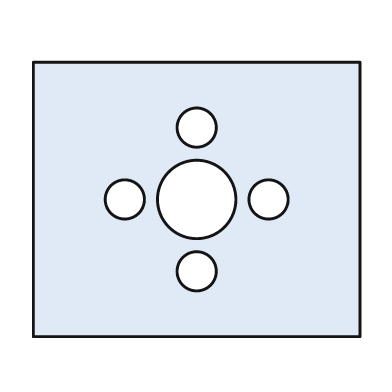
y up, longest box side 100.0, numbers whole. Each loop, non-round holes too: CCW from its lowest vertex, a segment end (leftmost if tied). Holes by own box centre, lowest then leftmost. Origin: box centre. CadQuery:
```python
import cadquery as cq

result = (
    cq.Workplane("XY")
    .moveTo(-50.0, -42.0)
    .lineTo(50.0, -42.0)
    .lineTo(50.0, 42.0)
    .lineTo(-50.0, 42.0)
    .close()
    .moveTo(0.0, -22.0)
    .circle(6.0)
    .moveTo(-22.0, 0.0)
    .circle(6.0)
    .moveTo(0.0, 0.0)
    .circle(12.0)
    .moveTo(22.0, 0.0)
    .circle(6.0)
    .moveTo(0.0, 22.0)
    .circle(6.0)
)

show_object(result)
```